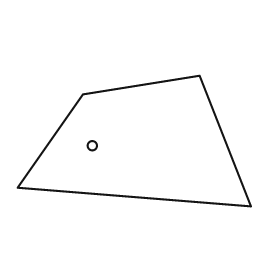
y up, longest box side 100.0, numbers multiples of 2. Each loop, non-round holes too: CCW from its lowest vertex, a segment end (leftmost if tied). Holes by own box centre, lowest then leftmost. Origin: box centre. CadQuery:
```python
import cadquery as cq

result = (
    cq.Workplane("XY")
    .moveTo(50.0, -28.0)
    .lineTo(28.0, 28.0)
    .lineTo(-22.0, 20.0)
    .lineTo(-50.0, -20.0)
    .close()
    .moveTo(-18.0, -2.0)
    .circle(2.0)
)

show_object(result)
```